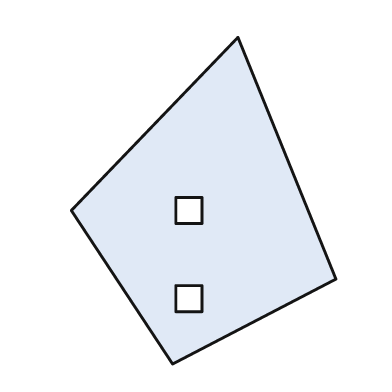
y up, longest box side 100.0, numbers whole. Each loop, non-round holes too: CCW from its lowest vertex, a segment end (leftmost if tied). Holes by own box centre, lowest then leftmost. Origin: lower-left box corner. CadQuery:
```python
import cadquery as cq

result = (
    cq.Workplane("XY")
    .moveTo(31.0, 0.0)
    .lineTo(81.0, 26.0)
    .lineTo(51.0, 100.0)
    .lineTo(0.0, 47.0)
    .close()
    .moveTo(32.0, 16.0)
    .lineTo(40.0, 16.0)
    .lineTo(40.0, 24.0)
    .lineTo(32.0, 24.0)
    .close()
    .moveTo(32.0, 43.0)
    .lineTo(40.0, 43.0)
    .lineTo(40.0, 51.0)
    .lineTo(32.0, 51.0)
    .close()
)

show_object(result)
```